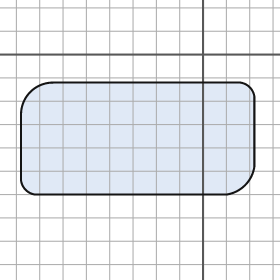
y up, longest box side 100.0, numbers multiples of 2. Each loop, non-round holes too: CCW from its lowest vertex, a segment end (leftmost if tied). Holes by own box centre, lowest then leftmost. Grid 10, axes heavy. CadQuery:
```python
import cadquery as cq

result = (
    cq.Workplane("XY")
    .moveTo(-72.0, -60.0)
    .lineTo(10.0, -60.0)
    .threePointArc((18.0, -56.0), (22.0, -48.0))
    .lineTo(22.0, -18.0)
    .threePointArc((20.0, -14.0), (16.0, -12.0))
    .lineTo(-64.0, -12.0)
    .threePointArc((-74.0, -16.0), (-78.0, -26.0))
    .lineTo(-78.0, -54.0)
    .threePointArc((-76.0, -58.0), (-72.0, -60.0))
    .close()
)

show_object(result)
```